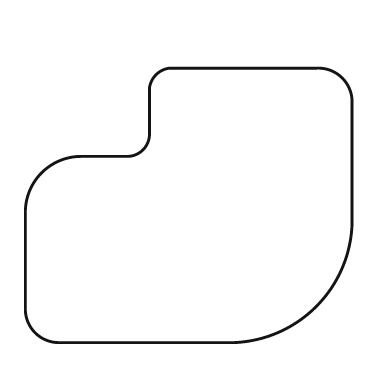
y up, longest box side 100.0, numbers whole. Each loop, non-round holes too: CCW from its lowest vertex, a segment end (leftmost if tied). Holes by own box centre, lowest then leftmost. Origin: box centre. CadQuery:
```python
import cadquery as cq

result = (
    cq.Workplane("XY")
    .moveTo(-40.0, -42.0)
    .lineTo(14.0, -42.0)
    .threePointArc((39.0, -31.0), (50.0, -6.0))
    .lineTo(50.0, 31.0)
    .threePointArc((47.0, 39.0), (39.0, 42.0))
    .lineTo(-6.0, 42.0)
    .threePointArc((-10.0, 40.0), (-12.0, 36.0))
    .lineTo(-12.0, 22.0)
    .threePointArc((-14.0, 17.0), (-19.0, 15.0))
    .lineTo(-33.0, 15.0)
    .threePointArc((-45.0, 10.0), (-50.0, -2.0))
    .lineTo(-50.0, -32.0)
    .threePointArc((-47.0, -39.0), (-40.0, -42.0))
    .close()
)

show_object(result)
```